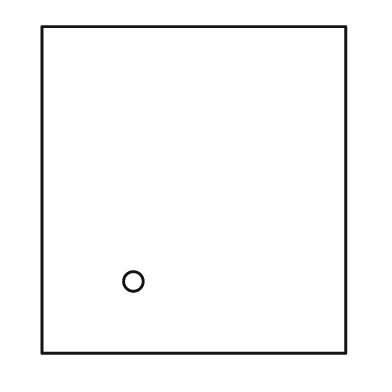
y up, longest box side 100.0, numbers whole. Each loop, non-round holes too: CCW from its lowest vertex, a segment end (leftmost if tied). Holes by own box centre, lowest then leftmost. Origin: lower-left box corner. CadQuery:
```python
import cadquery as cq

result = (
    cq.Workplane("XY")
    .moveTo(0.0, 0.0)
    .lineTo(93.0, 0.0)
    .lineTo(93.0, 100.0)
    .lineTo(0.0, 100.0)
    .close()
    .moveTo(28.0, 22.0)
    .circle(3.0)
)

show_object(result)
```